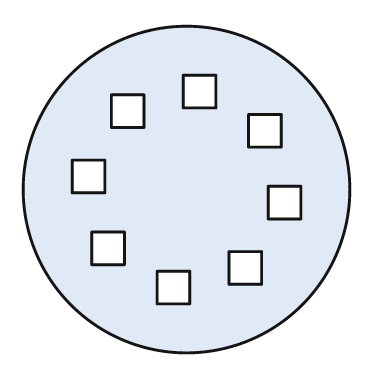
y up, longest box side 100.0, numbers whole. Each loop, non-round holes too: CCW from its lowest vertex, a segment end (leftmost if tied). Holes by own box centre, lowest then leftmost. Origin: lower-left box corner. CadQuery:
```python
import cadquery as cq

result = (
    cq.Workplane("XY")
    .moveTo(50.0, 50.0)
    .circle(50.0)
    .moveTo(41.0, 15.0)
    .lineTo(51.0, 15.0)
    .lineTo(51.0, 25.0)
    .lineTo(41.0, 25.0)
    .close()
    .moveTo(63.0, 21.0)
    .lineTo(73.0, 21.0)
    .lineTo(73.0, 31.0)
    .lineTo(63.0, 31.0)
    .close()
    .moveTo(21.0, 27.0)
    .lineTo(31.0, 27.0)
    .lineTo(31.0, 37.0)
    .lineTo(21.0, 37.0)
    .close()
    .moveTo(75.0, 41.0)
    .lineTo(85.0, 41.0)
    .lineTo(85.0, 51.0)
    .lineTo(75.0, 51.0)
    .close()
    .moveTo(15.0, 49.0)
    .lineTo(25.0, 49.0)
    .lineTo(25.0, 59.0)
    .lineTo(15.0, 59.0)
    .close()
    .moveTo(69.0, 63.0)
    .lineTo(79.0, 63.0)
    .lineTo(79.0, 73.0)
    .lineTo(69.0, 73.0)
    .close()
    .moveTo(27.0, 69.0)
    .lineTo(37.0, 69.0)
    .lineTo(37.0, 79.0)
    .lineTo(27.0, 79.0)
    .close()
    .moveTo(49.0, 75.0)
    .lineTo(59.0, 75.0)
    .lineTo(59.0, 85.0)
    .lineTo(49.0, 85.0)
    .close()
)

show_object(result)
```